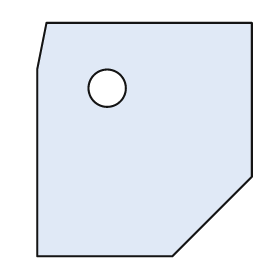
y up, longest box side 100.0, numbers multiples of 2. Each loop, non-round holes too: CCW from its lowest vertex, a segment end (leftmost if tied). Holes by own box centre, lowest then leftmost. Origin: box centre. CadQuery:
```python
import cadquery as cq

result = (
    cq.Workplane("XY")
    .moveTo(-46.0, -50.0)
    .lineTo(12.0, -50.0)
    .lineTo(46.0, -16.0)
    .lineTo(46.0, 50.0)
    .lineTo(-42.0, 50.0)
    .lineTo(-46.0, 30.0)
    .close()
    .moveTo(-16.0, 22.0)
    .circle(8.0)
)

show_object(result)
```